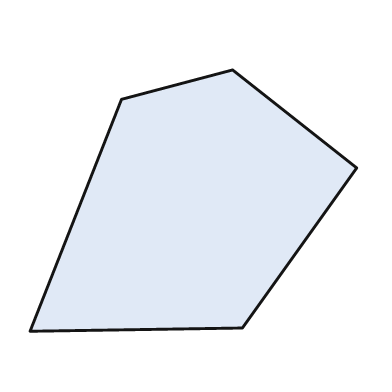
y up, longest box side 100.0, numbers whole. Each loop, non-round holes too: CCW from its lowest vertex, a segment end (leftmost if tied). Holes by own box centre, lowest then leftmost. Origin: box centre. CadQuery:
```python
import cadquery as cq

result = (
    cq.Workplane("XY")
    .moveTo(-50.0, -40.0)
    .lineTo(15.0, -39.0)
    .lineTo(50.0, 10.0)
    .lineTo(12.0, 40.0)
    .lineTo(-22.0, 31.0)
    .close()
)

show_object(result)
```